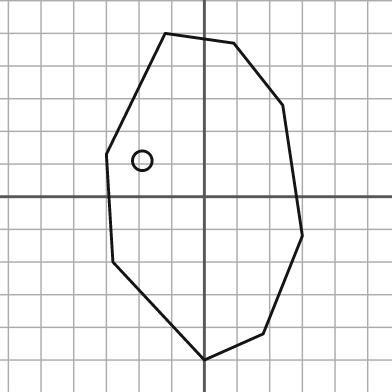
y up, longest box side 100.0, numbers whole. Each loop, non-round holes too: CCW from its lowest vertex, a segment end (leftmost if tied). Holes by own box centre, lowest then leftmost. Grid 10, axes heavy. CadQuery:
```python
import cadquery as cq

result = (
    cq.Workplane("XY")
    .moveTo(0.0, -50.0)
    .lineTo(18.0, -42.0)
    .lineTo(30.0, -12.0)
    .lineTo(24.0, 28.0)
    .lineTo(9.0, 47.0)
    .lineTo(-12.0, 50.0)
    .lineTo(-30.0, 13.0)
    .lineTo(-28.0, -20.0)
    .close()
    .moveTo(-19.0, 11.0)
    .circle(3.0)
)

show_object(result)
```